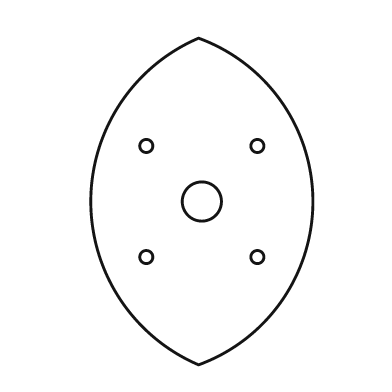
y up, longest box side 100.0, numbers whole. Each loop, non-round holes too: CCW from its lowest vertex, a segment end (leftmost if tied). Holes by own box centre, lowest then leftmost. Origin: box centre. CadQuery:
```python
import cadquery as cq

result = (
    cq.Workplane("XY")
    .moveTo(-1.0, -50.0)
    .threePointArc((34.0, 0.0), (-1.0, 50.0))
    .threePointArc((-34.0, 0.0), (-1.0, -50.0))
    .close()
    .moveTo(-17.0, -17.0)
    .circle(2.0)
    .moveTo(17.0, -17.0)
    .circle(2.0)
    .moveTo(0.0, 0.0)
    .circle(6.0)
    .moveTo(-17.0, 17.0)
    .circle(2.0)
    .moveTo(17.0, 17.0)
    .circle(2.0)
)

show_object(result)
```